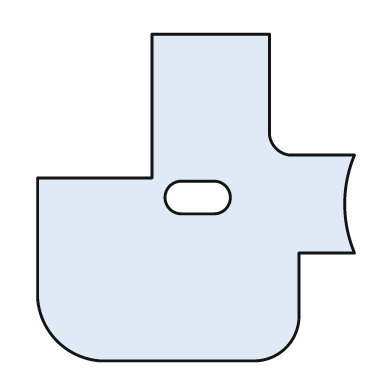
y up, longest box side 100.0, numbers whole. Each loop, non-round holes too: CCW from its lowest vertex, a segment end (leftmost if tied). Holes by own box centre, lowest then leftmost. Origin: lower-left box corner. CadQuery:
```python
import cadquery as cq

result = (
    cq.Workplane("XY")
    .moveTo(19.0, 0.0)
    .lineTo(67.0, 0.0)
    .threePointArc((76.0, 4.0), (80.0, 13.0))
    .lineTo(80.0, 33.0)
    .lineTo(97.0, 33.0)
    .threePointArc((94.0, 48.0), (97.0, 63.0))
    .lineTo(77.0, 63.0)
    .threePointArc((73.0, 65.0), (71.0, 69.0))
    .lineTo(71.0, 100.0)
    .lineTo(35.0, 100.0)
    .lineTo(35.0, 56.0)
    .lineTo(0.0, 56.0)
    .lineTo(0.0, 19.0)
    .threePointArc((6.0, 6.0), (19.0, 0.0))
    .close()
    .moveTo(44.0, 45.0)
    .lineTo(54.0, 45.0)
    .threePointArc((59.0, 50.0), (54.0, 55.0))
    .lineTo(44.0, 55.0)
    .threePointArc((39.0, 50.0), (44.0, 45.0))
    .close()
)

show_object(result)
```